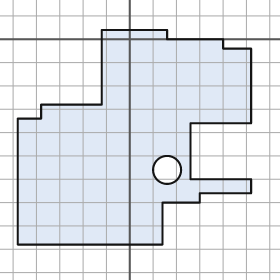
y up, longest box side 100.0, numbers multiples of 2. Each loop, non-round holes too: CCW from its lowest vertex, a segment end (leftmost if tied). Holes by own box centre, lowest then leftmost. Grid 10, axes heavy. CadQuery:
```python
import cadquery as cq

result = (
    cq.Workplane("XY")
    .moveTo(-48.0, -88.0)
    .lineTo(14.0, -88.0)
    .lineTo(14.0, -70.0)
    .lineTo(30.0, -70.0)
    .lineTo(30.0, -66.0)
    .lineTo(52.0, -66.0)
    .lineTo(52.0, -60.0)
    .lineTo(26.0, -60.0)
    .lineTo(26.0, -36.0)
    .lineTo(52.0, -36.0)
    .lineTo(52.0, -4.0)
    .lineTo(40.0, -4.0)
    .lineTo(40.0, 0.0)
    .lineTo(16.0, 0.0)
    .lineTo(16.0, 4.0)
    .lineTo(-12.0, 4.0)
    .lineTo(-12.0, -28.0)
    .lineTo(-38.0, -28.0)
    .lineTo(-38.0, -34.0)
    .lineTo(-48.0, -34.0)
    .close()
    .moveTo(16.0, -56.0)
    .circle(6.0)
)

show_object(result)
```